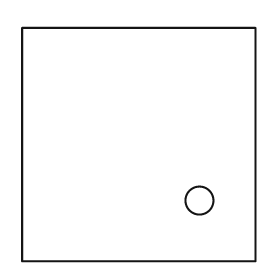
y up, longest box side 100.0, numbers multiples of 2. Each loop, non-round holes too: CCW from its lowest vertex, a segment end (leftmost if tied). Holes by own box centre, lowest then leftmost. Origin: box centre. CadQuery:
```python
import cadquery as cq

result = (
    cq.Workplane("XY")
    .moveTo(-50.0, -50.0)
    .lineTo(50.0, -50.0)
    .lineTo(50.0, 50.0)
    .lineTo(-50.0, 50.0)
    .close()
    .moveTo(26.0, -24.0)
    .circle(6.0)
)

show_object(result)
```